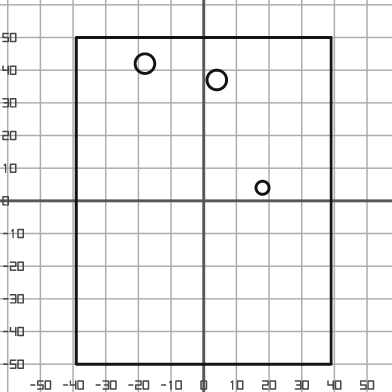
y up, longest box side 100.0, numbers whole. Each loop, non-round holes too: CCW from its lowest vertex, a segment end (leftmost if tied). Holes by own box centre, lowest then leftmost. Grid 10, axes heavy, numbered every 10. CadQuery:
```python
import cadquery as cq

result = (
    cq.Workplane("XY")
    .moveTo(-39.0, -50.0)
    .lineTo(39.0, -50.0)
    .lineTo(39.0, 50.0)
    .lineTo(-39.0, 50.0)
    .close()
    .moveTo(18.0, 4.0)
    .circle(2.0)
    .moveTo(4.0, 37.0)
    .circle(3.0)
    .moveTo(-18.0, 42.0)
    .circle(3.0)
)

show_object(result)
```